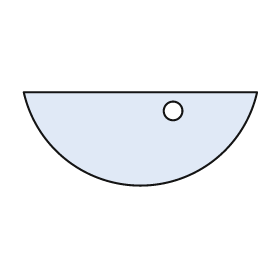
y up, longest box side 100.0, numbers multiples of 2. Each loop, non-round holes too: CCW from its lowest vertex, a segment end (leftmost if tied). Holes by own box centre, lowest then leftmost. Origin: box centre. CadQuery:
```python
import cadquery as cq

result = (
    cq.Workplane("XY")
    .moveTo(-50.0, 20.0)
    .threePointArc((0.0, -20.0), (50.0, 20.0))
    .close()
    .moveTo(14.0, 12.0)
    .circle(4.0)
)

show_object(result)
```